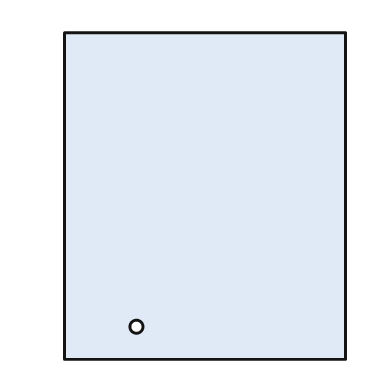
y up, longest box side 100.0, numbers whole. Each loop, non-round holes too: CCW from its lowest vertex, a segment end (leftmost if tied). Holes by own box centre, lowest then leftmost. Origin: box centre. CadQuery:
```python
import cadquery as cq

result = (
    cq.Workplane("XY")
    .moveTo(-43.0, -50.0)
    .lineTo(43.0, -50.0)
    .lineTo(43.0, 50.0)
    .lineTo(-43.0, 50.0)
    .close()
    .moveTo(-21.0, -40.0)
    .circle(2.0)
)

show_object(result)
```